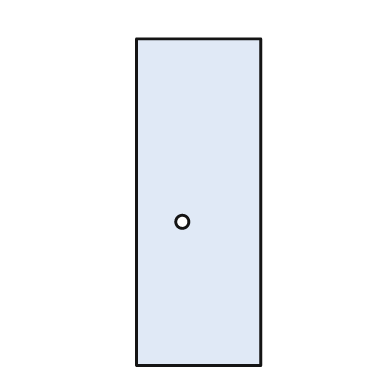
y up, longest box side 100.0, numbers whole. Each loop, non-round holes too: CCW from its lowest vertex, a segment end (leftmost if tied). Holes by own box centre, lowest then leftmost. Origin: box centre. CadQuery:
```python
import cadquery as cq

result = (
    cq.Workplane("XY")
    .moveTo(-19.0, -50.0)
    .lineTo(19.0, -50.0)
    .lineTo(19.0, 50.0)
    .lineTo(-19.0, 50.0)
    .close()
    .moveTo(-5.0, -6.0)
    .circle(2.0)
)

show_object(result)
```